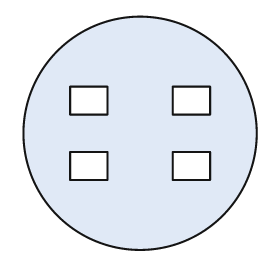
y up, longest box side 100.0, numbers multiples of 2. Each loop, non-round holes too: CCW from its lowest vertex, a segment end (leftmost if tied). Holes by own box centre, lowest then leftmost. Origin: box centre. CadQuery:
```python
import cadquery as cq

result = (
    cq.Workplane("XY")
    .moveTo(0.0, 0.0)
    .circle(50.0)
    .moveTo(-30.0, -20.0)
    .lineTo(-14.0, -20.0)
    .lineTo(-14.0, -8.0)
    .lineTo(-30.0, -8.0)
    .close()
    .moveTo(14.0, -20.0)
    .lineTo(30.0, -20.0)
    .lineTo(30.0, -8.0)
    .lineTo(14.0, -8.0)
    .close()
    .moveTo(-30.0, 8.0)
    .lineTo(-14.0, 8.0)
    .lineTo(-14.0, 20.0)
    .lineTo(-30.0, 20.0)
    .close()
    .moveTo(14.0, 8.0)
    .lineTo(30.0, 8.0)
    .lineTo(30.0, 20.0)
    .lineTo(14.0, 20.0)
    .close()
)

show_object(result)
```